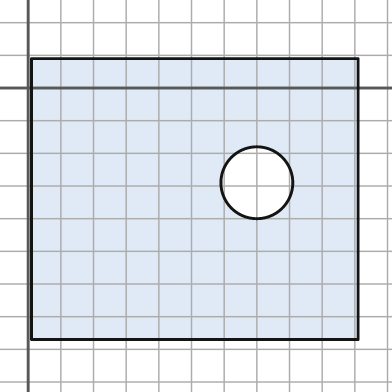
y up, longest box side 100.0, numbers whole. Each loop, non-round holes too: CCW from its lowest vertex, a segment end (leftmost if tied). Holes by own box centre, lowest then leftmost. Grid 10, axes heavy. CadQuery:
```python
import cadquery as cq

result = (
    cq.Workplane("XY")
    .moveTo(1.0, -77.0)
    .lineTo(101.0, -77.0)
    .lineTo(101.0, 9.0)
    .lineTo(1.0, 9.0)
    .close()
    .moveTo(70.0, -29.0)
    .circle(11.0)
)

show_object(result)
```